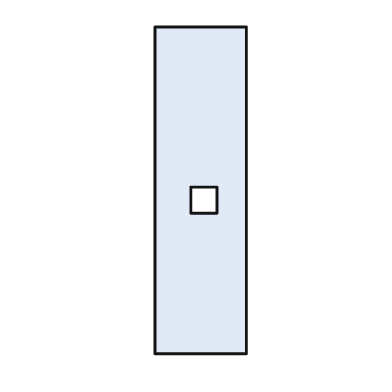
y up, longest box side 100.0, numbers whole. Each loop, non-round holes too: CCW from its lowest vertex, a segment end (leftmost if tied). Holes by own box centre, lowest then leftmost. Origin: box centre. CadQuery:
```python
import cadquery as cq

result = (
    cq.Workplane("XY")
    .moveTo(-14.0, -50.0)
    .lineTo(14.0, -50.0)
    .lineTo(14.0, 50.0)
    .lineTo(-14.0, 50.0)
    .close()
    .moveTo(-3.0, -7.0)
    .lineTo(5.0, -7.0)
    .lineTo(5.0, 1.0)
    .lineTo(-3.0, 1.0)
    .close()
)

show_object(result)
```